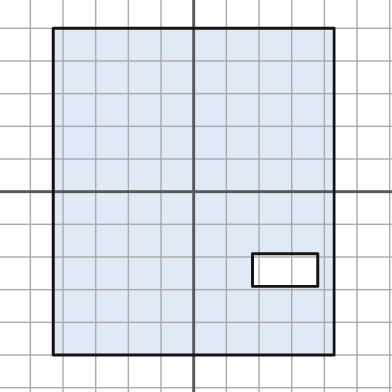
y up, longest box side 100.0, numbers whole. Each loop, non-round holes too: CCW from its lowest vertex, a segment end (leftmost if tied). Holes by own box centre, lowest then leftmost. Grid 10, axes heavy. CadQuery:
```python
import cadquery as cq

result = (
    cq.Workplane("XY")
    .moveTo(-43.0, -50.0)
    .lineTo(43.0, -50.0)
    .lineTo(43.0, 50.0)
    .lineTo(-43.0, 50.0)
    .close()
    .moveTo(18.0, -29.0)
    .lineTo(38.0, -29.0)
    .lineTo(38.0, -19.0)
    .lineTo(18.0, -19.0)
    .close()
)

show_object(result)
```